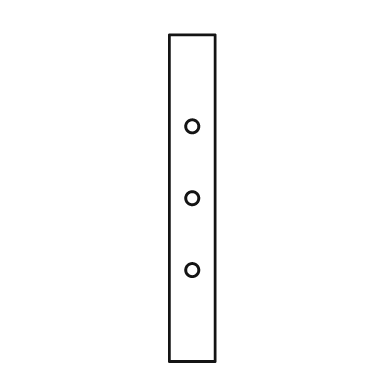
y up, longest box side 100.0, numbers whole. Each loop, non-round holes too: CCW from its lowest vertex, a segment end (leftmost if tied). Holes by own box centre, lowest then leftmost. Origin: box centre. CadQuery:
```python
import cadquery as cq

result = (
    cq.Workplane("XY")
    .moveTo(-7.0, -50.0)
    .lineTo(7.0, -50.0)
    .lineTo(7.0, 50.0)
    .lineTo(-7.0, 50.0)
    .close()
    .moveTo(0.0, -22.0)
    .circle(2.0)
    .moveTo(0.0, 0.0)
    .circle(2.0)
    .moveTo(0.0, 22.0)
    .circle(2.0)
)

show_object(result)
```